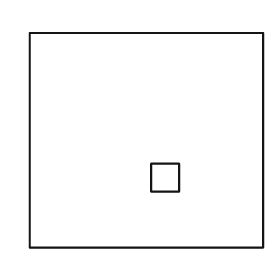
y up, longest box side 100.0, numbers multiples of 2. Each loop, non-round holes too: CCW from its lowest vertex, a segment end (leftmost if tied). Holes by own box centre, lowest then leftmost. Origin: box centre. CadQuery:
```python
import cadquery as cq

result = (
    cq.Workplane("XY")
    .moveTo(-50.0, -46.0)
    .lineTo(50.0, -46.0)
    .lineTo(50.0, 46.0)
    .lineTo(-50.0, 46.0)
    .close()
    .moveTo(2.0, -22.0)
    .lineTo(14.0, -22.0)
    .lineTo(14.0, -10.0)
    .lineTo(2.0, -10.0)
    .close()
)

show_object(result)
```